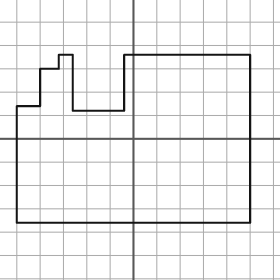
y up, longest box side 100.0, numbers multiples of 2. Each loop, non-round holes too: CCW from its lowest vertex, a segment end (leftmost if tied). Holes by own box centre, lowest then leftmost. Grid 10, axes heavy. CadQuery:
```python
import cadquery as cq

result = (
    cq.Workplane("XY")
    .moveTo(-50.0, -36.0)
    .lineTo(50.0, -36.0)
    .lineTo(50.0, 36.0)
    .lineTo(-4.0, 36.0)
    .lineTo(-4.0, 12.0)
    .lineTo(-26.0, 12.0)
    .lineTo(-26.0, 36.0)
    .lineTo(-32.0, 36.0)
    .lineTo(-32.0, 30.0)
    .lineTo(-40.0, 30.0)
    .lineTo(-40.0, 14.0)
    .lineTo(-50.0, 14.0)
    .close()
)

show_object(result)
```